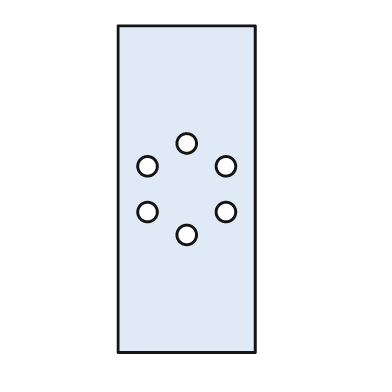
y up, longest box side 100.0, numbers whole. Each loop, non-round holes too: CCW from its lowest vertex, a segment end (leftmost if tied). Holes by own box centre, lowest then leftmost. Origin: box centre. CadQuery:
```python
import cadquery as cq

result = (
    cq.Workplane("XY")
    .moveTo(-21.0, -50.0)
    .lineTo(21.0, -50.0)
    .lineTo(21.0, 50.0)
    .lineTo(-21.0, 50.0)
    .close()
    .moveTo(0.0, -14.0)
    .circle(3.0)
    .moveTo(-12.0, -7.0)
    .circle(3.0)
    .moveTo(12.0, -7.0)
    .circle(3.0)
    .moveTo(-12.0, 7.0)
    .circle(3.0)
    .moveTo(12.0, 7.0)
    .circle(3.0)
    .moveTo(0.0, 14.0)
    .circle(3.0)
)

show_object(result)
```